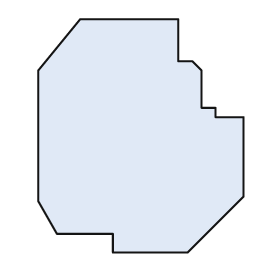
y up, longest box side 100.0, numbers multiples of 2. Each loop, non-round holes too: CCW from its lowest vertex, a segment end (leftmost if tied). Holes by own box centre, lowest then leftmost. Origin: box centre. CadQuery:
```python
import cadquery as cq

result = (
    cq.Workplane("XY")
    .moveTo(-12.0, -50.0)
    .lineTo(20.0, -50.0)
    .lineTo(44.0, -26.0)
    .lineTo(44.0, 8.0)
    .lineTo(32.0, 8.0)
    .lineTo(32.0, 12.0)
    .lineTo(26.0, 12.0)
    .lineTo(26.0, 28.0)
    .lineTo(22.0, 32.0)
    .lineTo(16.0, 32.0)
    .lineTo(16.0, 50.0)
    .lineTo(-26.0, 50.0)
    .lineTo(-44.0, 28.0)
    .lineTo(-44.0, -28.0)
    .lineTo(-36.0, -42.0)
    .lineTo(-12.0, -42.0)
    .close()
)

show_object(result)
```